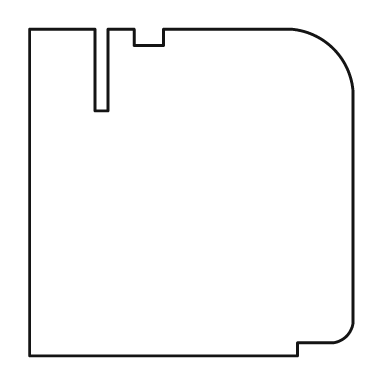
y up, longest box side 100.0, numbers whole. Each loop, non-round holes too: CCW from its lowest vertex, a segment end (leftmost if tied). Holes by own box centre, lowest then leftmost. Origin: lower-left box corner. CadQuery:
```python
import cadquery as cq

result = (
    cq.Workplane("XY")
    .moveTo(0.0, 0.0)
    .lineTo(82.0, 0.0)
    .lineTo(82.0, 4.0)
    .lineTo(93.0, 4.0)
    .threePointArc((97.0, 6.0), (99.0, 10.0))
    .lineTo(99.0, 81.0)
    .threePointArc((93.0, 94.0), (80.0, 100.0))
    .lineTo(41.0, 100.0)
    .lineTo(41.0, 95.0)
    .lineTo(32.0, 95.0)
    .lineTo(32.0, 100.0)
    .lineTo(24.0, 100.0)
    .lineTo(24.0, 75.0)
    .lineTo(20.0, 75.0)
    .lineTo(20.0, 100.0)
    .lineTo(0.0, 100.0)
    .close()
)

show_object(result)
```